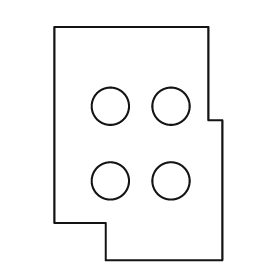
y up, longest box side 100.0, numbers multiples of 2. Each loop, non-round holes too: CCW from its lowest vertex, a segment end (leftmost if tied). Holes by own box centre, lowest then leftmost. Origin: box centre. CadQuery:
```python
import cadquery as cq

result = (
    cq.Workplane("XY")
    .moveTo(-14.0, -50.0)
    .lineTo(36.0, -50.0)
    .lineTo(36.0, 10.0)
    .lineTo(30.0, 10.0)
    .lineTo(30.0, 50.0)
    .lineTo(-36.0, 50.0)
    .lineTo(-36.0, -34.0)
    .lineTo(-14.0, -34.0)
    .close()
    .moveTo(-12.0, -16.0)
    .circle(8.0)
    .moveTo(14.0, -16.0)
    .circle(8.0)
    .moveTo(-12.0, 16.0)
    .circle(8.0)
    .moveTo(14.0, 16.0)
    .circle(8.0)
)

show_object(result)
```